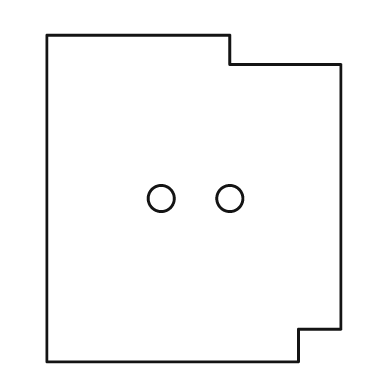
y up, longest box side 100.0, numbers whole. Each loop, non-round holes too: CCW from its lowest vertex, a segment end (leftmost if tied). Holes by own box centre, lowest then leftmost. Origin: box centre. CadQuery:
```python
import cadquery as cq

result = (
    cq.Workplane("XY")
    .moveTo(-45.0, -50.0)
    .lineTo(32.0, -50.0)
    .lineTo(32.0, -40.0)
    .lineTo(45.0, -40.0)
    .lineTo(45.0, 41.0)
    .lineTo(11.0, 41.0)
    .lineTo(11.0, 50.0)
    .lineTo(-45.0, 50.0)
    .close()
    .moveTo(-10.0, 0.0)
    .circle(4.0)
    .moveTo(11.0, 0.0)
    .circle(4.0)
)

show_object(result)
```